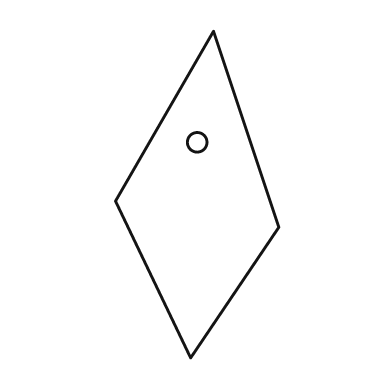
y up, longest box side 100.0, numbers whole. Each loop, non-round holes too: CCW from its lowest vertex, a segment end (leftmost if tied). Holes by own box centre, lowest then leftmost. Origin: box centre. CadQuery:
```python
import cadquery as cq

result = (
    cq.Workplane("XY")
    .moveTo(-2.0, -50.0)
    .lineTo(25.0, -10.0)
    .lineTo(5.0, 50.0)
    .lineTo(-25.0, -2.0)
    .close()
    .moveTo(0.0, 16.0)
    .circle(3.0)
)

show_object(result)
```